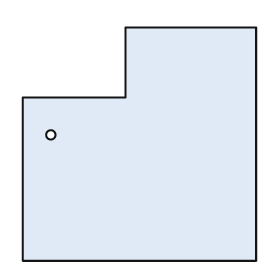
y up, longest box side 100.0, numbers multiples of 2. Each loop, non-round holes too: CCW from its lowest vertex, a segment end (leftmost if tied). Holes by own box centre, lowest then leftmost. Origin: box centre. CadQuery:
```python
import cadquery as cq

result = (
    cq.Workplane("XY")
    .moveTo(-50.0, -50.0)
    .lineTo(50.0, -50.0)
    .lineTo(50.0, 50.0)
    .lineTo(-6.0, 50.0)
    .lineTo(-6.0, 20.0)
    .lineTo(-50.0, 20.0)
    .close()
    .moveTo(-38.0, 4.0)
    .circle(2.0)
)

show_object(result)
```